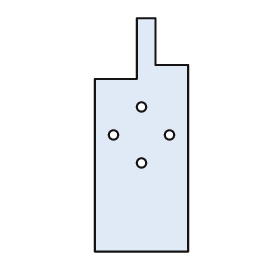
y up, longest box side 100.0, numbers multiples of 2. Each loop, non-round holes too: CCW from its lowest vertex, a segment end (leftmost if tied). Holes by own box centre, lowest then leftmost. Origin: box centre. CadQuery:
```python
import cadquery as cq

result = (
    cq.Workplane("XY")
    .moveTo(-20.0, -50.0)
    .lineTo(20.0, -50.0)
    .lineTo(20.0, 30.0)
    .lineTo(6.0, 30.0)
    .lineTo(6.0, 50.0)
    .lineTo(-2.0, 50.0)
    .lineTo(-2.0, 24.0)
    .lineTo(-20.0, 24.0)
    .close()
    .moveTo(0.0, -12.0)
    .circle(2.0)
    .moveTo(-12.0, 0.0)
    .circle(2.0)
    .moveTo(12.0, 0.0)
    .circle(2.0)
    .moveTo(0.0, 12.0)
    .circle(2.0)
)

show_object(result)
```